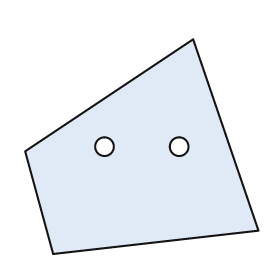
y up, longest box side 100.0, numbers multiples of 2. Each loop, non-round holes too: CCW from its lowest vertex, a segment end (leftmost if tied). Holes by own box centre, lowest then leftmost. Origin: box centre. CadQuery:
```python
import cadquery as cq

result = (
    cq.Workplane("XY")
    .moveTo(-38.0, -46.0)
    .lineTo(50.0, -36.0)
    .lineTo(22.0, 46.0)
    .lineTo(-50.0, -2.0)
    .close()
    .moveTo(-16.0, 0.0)
    .circle(4.0)
    .moveTo(16.0, 0.0)
    .circle(4.0)
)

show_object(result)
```